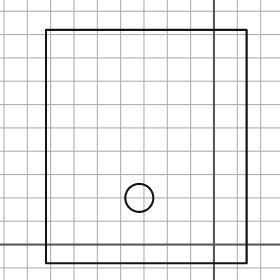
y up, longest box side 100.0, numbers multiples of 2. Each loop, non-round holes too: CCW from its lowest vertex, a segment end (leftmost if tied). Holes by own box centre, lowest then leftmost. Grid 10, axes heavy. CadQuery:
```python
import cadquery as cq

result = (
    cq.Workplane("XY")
    .moveTo(-72.0, -8.0)
    .lineTo(14.0, -8.0)
    .lineTo(14.0, 92.0)
    .lineTo(-72.0, 92.0)
    .close()
    .moveTo(-32.0, 20.0)
    .circle(6.0)
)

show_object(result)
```